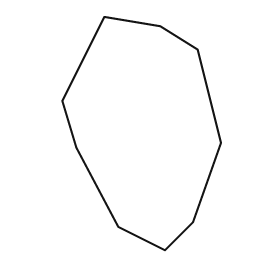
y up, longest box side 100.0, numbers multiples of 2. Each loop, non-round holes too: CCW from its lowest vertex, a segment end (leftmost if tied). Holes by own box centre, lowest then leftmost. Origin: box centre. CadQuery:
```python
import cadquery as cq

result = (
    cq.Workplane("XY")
    .moveTo(10.0, -50.0)
    .lineTo(22.0, -38.0)
    .lineTo(34.0, -4.0)
    .lineTo(24.0, 36.0)
    .lineTo(8.0, 46.0)
    .lineTo(-16.0, 50.0)
    .lineTo(-34.0, 14.0)
    .lineTo(-28.0, -6.0)
    .lineTo(-10.0, -40.0)
    .close()
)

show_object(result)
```